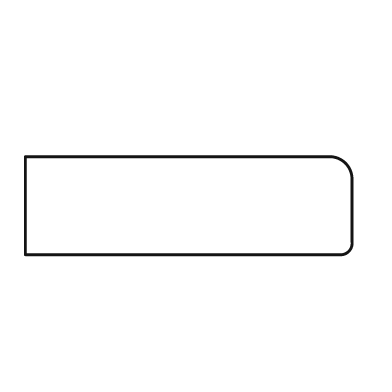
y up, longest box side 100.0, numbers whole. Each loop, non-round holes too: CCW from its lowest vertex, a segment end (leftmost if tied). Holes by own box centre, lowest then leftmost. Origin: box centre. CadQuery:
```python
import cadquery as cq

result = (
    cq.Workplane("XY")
    .moveTo(-50.0, -15.0)
    .lineTo(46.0, -15.0)
    .threePointArc((49.0, -14.0), (50.0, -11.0))
    .lineTo(50.0, 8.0)
    .threePointArc((48.0, 13.0), (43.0, 15.0))
    .lineTo(-50.0, 15.0)
    .close()
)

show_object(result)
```